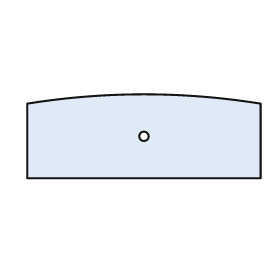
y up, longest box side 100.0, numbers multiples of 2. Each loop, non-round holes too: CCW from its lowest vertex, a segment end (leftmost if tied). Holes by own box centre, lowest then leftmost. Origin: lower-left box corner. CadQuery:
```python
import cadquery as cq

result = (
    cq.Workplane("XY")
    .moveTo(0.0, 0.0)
    .lineTo(100.0, 0.0)
    .lineTo(100.0, 32.0)
    .threePointArc((50.0, 36.0), (0.0, 32.0))
    .close()
    .moveTo(50.0, 18.0)
    .circle(2.0)
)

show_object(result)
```